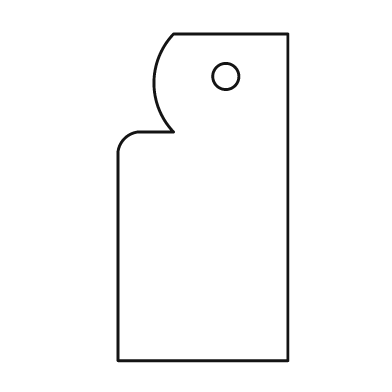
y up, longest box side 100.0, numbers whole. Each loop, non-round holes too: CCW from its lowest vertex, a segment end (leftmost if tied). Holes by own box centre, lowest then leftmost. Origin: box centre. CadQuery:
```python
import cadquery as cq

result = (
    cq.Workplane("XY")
    .moveTo(-26.0, -50.0)
    .lineTo(26.0, -50.0)
    .lineTo(26.0, 50.0)
    .lineTo(-9.0, 50.0)
    .threePointArc((-15.0, 35.0), (-9.0, 20.0))
    .lineTo(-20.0, 20.0)
    .threePointArc((-24.0, 18.0), (-26.0, 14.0))
    .close()
    .moveTo(7.0, 37.0)
    .circle(4.0)
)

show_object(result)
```